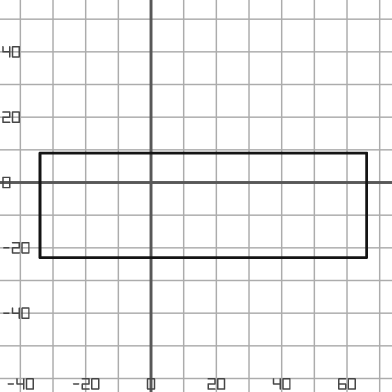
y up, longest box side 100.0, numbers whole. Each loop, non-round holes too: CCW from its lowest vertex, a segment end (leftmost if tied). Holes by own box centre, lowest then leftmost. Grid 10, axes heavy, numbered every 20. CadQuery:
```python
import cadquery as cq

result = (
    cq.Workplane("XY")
    .moveTo(-34.0, -23.0)
    .lineTo(66.0, -23.0)
    .lineTo(66.0, 9.0)
    .lineTo(-34.0, 9.0)
    .close()
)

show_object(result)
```